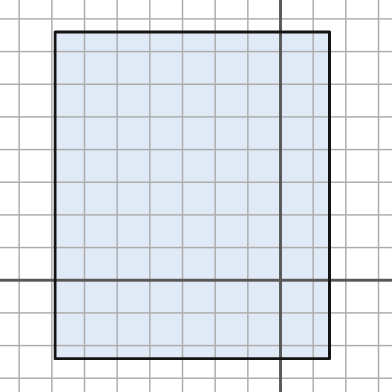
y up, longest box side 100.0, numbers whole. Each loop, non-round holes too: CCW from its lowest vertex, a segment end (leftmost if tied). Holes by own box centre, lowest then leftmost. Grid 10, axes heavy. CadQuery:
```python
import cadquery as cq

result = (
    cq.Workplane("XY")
    .moveTo(-69.0, -24.0)
    .lineTo(15.0, -24.0)
    .lineTo(15.0, 76.0)
    .lineTo(-69.0, 76.0)
    .close()
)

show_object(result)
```